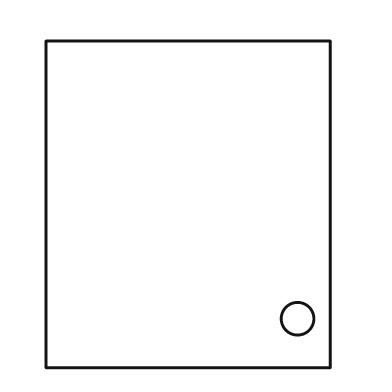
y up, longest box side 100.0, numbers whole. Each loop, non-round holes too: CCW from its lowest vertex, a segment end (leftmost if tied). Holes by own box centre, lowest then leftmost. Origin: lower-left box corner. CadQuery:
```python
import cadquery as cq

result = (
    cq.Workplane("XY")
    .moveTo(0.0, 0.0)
    .lineTo(87.0, 0.0)
    .lineTo(87.0, 100.0)
    .lineTo(0.0, 100.0)
    .close()
    .moveTo(77.0, 15.0)
    .circle(5.0)
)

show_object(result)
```